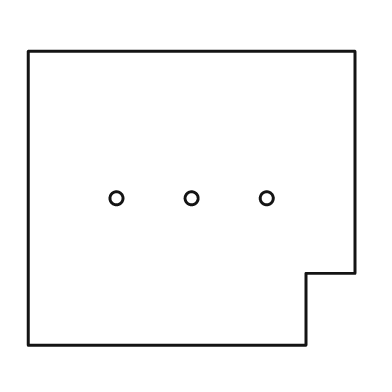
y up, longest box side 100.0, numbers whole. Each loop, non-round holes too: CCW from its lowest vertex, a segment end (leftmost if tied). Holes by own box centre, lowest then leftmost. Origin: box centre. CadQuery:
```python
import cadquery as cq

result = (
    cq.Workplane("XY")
    .moveTo(-50.0, -45.0)
    .lineTo(35.0, -45.0)
    .lineTo(35.0, -23.0)
    .lineTo(50.0, -23.0)
    .lineTo(50.0, 45.0)
    .lineTo(-50.0, 45.0)
    .close()
    .moveTo(-23.0, 0.0)
    .circle(2.0)
    .moveTo(0.0, 0.0)
    .circle(2.0)
    .moveTo(23.0, 0.0)
    .circle(2.0)
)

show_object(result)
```